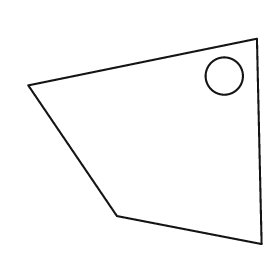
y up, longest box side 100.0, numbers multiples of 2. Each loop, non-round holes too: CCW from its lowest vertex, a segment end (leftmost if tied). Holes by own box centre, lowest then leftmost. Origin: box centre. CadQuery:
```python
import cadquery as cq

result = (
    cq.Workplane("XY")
    .moveTo(50.0, -44.0)
    .lineTo(48.0, 44.0)
    .lineTo(-50.0, 24.0)
    .lineTo(-12.0, -32.0)
    .close()
    .moveTo(34.0, 28.0)
    .circle(8.0)
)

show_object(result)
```